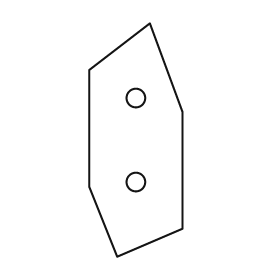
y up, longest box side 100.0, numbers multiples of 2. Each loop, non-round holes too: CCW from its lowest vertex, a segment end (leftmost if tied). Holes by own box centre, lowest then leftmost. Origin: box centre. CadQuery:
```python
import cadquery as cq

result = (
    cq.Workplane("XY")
    .moveTo(-8.0, -50.0)
    .lineTo(20.0, -38.0)
    .lineTo(20.0, 12.0)
    .lineTo(6.0, 50.0)
    .lineTo(-20.0, 30.0)
    .lineTo(-20.0, -20.0)
    .close()
    .moveTo(0.0, -18.0)
    .circle(4.0)
    .moveTo(0.0, 18.0)
    .circle(4.0)
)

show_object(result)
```